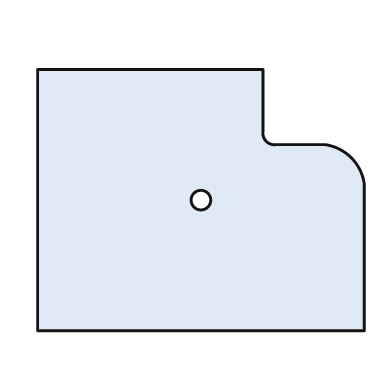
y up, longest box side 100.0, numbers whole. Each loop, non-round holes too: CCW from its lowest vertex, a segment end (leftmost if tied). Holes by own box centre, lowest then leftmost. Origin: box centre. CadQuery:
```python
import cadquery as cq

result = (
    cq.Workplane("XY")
    .moveTo(-50.0, -40.0)
    .lineTo(50.0, -40.0)
    .lineTo(50.0, 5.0)
    .threePointArc((46.0, 13.0), (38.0, 17.0))
    .lineTo(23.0, 17.0)
    .threePointArc((20.0, 18.0), (19.0, 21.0))
    .lineTo(19.0, 40.0)
    .lineTo(-50.0, 40.0)
    .close()
    .moveTo(0.0, 0.0)
    .circle(3.0)
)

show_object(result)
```